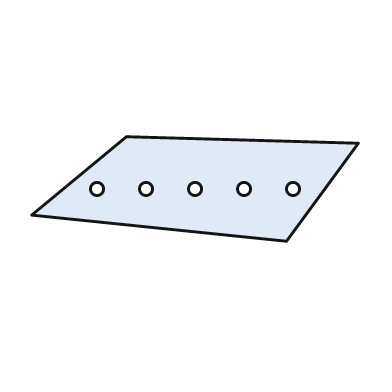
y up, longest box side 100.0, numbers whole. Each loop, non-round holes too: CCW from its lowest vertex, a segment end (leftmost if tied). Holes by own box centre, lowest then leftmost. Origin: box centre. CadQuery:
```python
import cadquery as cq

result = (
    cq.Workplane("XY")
    .moveTo(28.0, -16.0)
    .lineTo(50.0, 14.0)
    .lineTo(-21.0, 16.0)
    .lineTo(-50.0, -8.0)
    .close()
    .moveTo(-30.0, 0.0)
    .circle(2.0)
    .moveTo(-15.0, 0.0)
    .circle(2.0)
    .moveTo(0.0, 0.0)
    .circle(2.0)
    .moveTo(15.0, 0.0)
    .circle(2.0)
    .moveTo(30.0, 0.0)
    .circle(2.0)
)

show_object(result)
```